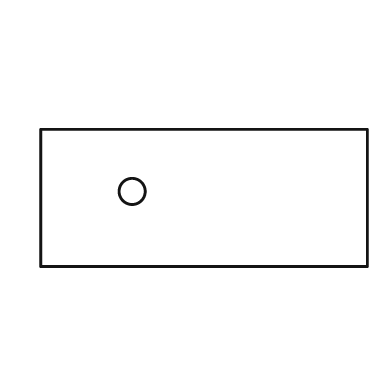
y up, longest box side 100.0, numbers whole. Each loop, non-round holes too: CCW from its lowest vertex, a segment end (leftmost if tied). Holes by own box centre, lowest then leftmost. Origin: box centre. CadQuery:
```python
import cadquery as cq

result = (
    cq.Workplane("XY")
    .moveTo(-50.0, -21.0)
    .lineTo(50.0, -21.0)
    .lineTo(50.0, 21.0)
    .lineTo(-50.0, 21.0)
    .close()
    .moveTo(-22.0, 2.0)
    .circle(4.0)
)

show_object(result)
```